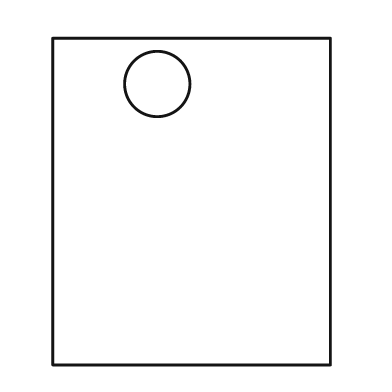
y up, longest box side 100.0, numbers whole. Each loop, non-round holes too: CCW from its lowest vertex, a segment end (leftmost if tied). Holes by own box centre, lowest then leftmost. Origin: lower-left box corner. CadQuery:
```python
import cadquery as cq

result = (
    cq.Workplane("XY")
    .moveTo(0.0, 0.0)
    .lineTo(85.0, 0.0)
    .lineTo(85.0, 100.0)
    .lineTo(0.0, 100.0)
    .close()
    .moveTo(32.0, 86.0)
    .circle(10.0)
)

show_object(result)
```